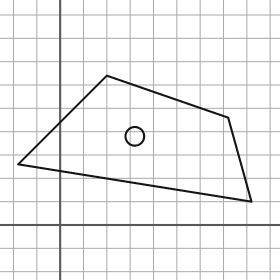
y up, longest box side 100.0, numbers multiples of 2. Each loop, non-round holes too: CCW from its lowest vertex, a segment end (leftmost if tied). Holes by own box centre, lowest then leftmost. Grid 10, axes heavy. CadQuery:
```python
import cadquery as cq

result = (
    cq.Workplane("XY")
    .moveTo(82.0, 10.0)
    .lineTo(72.0, 46.0)
    .lineTo(20.0, 64.0)
    .lineTo(-18.0, 26.0)
    .close()
    .moveTo(32.0, 38.0)
    .circle(4.0)
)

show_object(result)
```